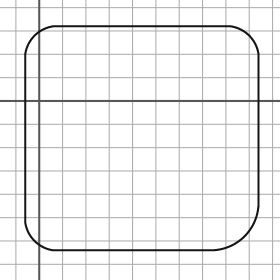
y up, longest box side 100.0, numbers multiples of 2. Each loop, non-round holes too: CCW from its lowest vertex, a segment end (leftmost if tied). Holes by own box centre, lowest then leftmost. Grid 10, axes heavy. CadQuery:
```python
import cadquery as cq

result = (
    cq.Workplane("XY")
    .moveTo(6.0, -64.0)
    .lineTo(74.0, -64.0)
    .threePointArc((88.0, -58.0), (94.0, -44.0))
    .lineTo(94.0, 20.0)
    .threePointArc((90.0, 28.0), (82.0, 32.0))
    .lineTo(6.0, 32.0)
    .threePointArc((-2.0, 28.0), (-6.0, 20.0))
    .lineTo(-6.0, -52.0)
    .threePointArc((-2.0, -60.0), (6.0, -64.0))
    .close()
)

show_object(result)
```